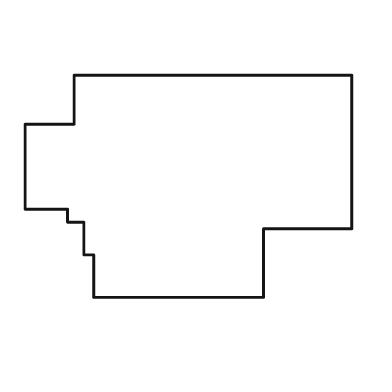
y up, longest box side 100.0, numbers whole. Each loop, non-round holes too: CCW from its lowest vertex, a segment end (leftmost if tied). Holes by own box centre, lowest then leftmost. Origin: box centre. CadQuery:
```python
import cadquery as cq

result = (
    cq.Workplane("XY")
    .moveTo(-29.0, -34.0)
    .lineTo(23.0, -34.0)
    .lineTo(23.0, -13.0)
    .lineTo(50.0, -13.0)
    .lineTo(50.0, 34.0)
    .lineTo(-35.0, 34.0)
    .lineTo(-35.0, 19.0)
    .lineTo(-50.0, 19.0)
    .lineTo(-50.0, -7.0)
    .lineTo(-37.0, -7.0)
    .lineTo(-37.0, -11.0)
    .lineTo(-32.0, -11.0)
    .lineTo(-32.0, -21.0)
    .lineTo(-29.0, -21.0)
    .close()
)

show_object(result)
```